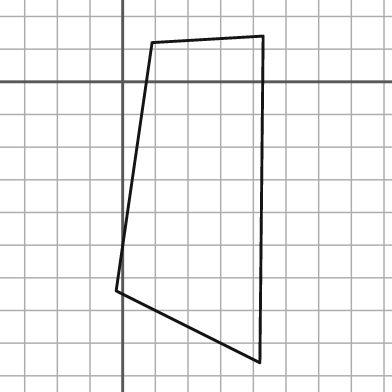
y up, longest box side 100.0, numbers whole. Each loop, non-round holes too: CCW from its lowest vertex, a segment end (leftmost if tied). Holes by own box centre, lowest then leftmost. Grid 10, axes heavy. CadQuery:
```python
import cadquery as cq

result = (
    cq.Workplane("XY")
    .moveTo(42.0, -86.0)
    .lineTo(43.0, 14.0)
    .lineTo(9.0, 12.0)
    .lineTo(-2.0, -64.0)
    .close()
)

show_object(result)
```